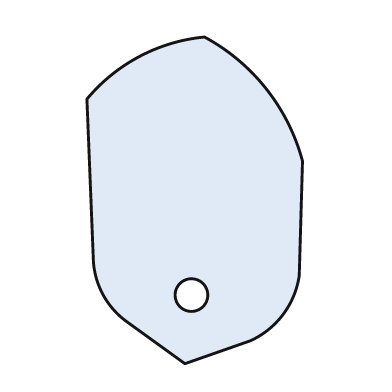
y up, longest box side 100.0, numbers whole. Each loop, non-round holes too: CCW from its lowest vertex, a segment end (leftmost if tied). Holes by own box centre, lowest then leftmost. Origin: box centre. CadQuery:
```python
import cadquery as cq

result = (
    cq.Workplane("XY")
    .moveTo(-3.0, -50.0)
    .lineTo(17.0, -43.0)
    .threePointArc((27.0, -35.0), (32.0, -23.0))
    .lineTo(33.0, 12.0)
    .threePointArc((22.0, 34.0), (3.0, 50.0))
    .threePointArc((-17.0, 44.0), (-33.0, 31.0))
    .lineTo(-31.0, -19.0)
    .threePointArc((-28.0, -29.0), (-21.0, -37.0))
    .close()
    .moveTo(-1.0, -29.0)
    .circle(5.0)
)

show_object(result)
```